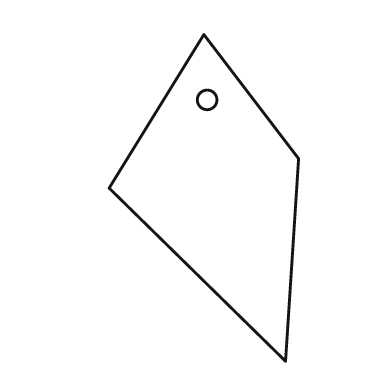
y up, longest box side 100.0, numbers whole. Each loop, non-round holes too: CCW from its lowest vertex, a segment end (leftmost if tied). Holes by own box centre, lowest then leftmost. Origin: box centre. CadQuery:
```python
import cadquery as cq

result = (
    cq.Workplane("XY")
    .moveTo(25.0, -50.0)
    .lineTo(29.0, 12.0)
    .lineTo(0.0, 50.0)
    .lineTo(-29.0, 3.0)
    .close()
    .moveTo(1.0, 30.0)
    .circle(3.0)
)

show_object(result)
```